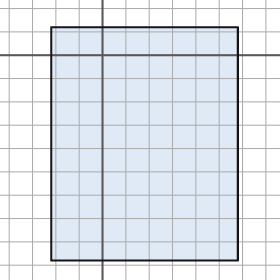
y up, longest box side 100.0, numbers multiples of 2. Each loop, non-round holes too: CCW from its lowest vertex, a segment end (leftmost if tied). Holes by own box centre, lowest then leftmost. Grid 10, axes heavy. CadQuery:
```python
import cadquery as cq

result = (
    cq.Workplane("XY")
    .moveTo(-22.0, -88.0)
    .lineTo(58.0, -88.0)
    .lineTo(58.0, 12.0)
    .lineTo(-22.0, 12.0)
    .close()
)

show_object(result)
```